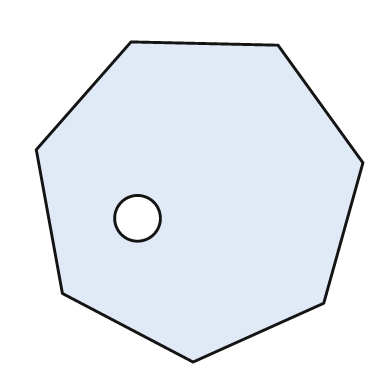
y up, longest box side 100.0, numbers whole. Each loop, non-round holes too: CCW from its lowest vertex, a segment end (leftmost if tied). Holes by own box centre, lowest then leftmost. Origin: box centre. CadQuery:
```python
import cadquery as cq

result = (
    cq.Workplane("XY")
    .moveTo(-2.0, -49.0)
    .lineTo(38.0, -31.0)
    .lineTo(50.0, 12.0)
    .lineTo(24.0, 48.0)
    .lineTo(-21.0, 49.0)
    .lineTo(-50.0, 16.0)
    .lineTo(-42.0, -28.0)
    .close()
    .moveTo(-19.0, -5.0)
    .circle(7.0)
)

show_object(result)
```